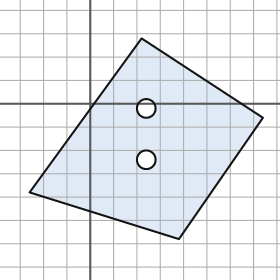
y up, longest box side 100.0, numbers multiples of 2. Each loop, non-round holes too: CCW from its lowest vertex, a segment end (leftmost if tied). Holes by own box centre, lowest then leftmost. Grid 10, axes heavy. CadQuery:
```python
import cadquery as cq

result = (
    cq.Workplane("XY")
    .moveTo(38.0, -58.0)
    .lineTo(74.0, -6.0)
    .lineTo(22.0, 28.0)
    .lineTo(-26.0, -38.0)
    .close()
    .moveTo(24.0, -24.0)
    .circle(4.0)
    .moveTo(24.0, -2.0)
    .circle(4.0)
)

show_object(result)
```